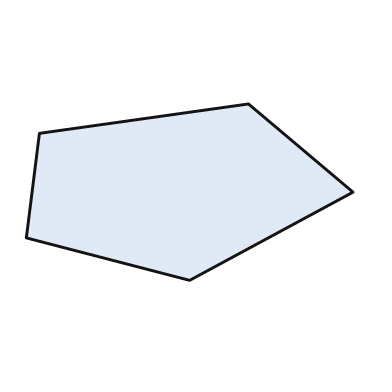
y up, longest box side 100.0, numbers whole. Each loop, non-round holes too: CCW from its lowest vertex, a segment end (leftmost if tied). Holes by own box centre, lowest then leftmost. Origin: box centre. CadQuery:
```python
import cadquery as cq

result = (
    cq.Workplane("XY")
    .moveTo(0.0, -27.0)
    .lineTo(50.0, 0.0)
    .lineTo(18.0, 27.0)
    .lineTo(-46.0, 18.0)
    .lineTo(-50.0, -14.0)
    .close()
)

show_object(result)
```